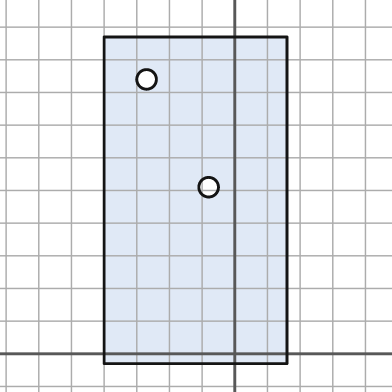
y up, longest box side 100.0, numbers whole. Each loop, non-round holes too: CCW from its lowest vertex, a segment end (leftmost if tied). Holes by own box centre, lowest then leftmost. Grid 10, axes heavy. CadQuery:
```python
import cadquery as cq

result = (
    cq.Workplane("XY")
    .moveTo(-40.0, -3.0)
    .lineTo(16.0, -3.0)
    .lineTo(16.0, 97.0)
    .lineTo(-40.0, 97.0)
    .close()
    .moveTo(-8.0, 51.0)
    .circle(3.0)
    .moveTo(-27.0, 84.0)
    .circle(3.0)
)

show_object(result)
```